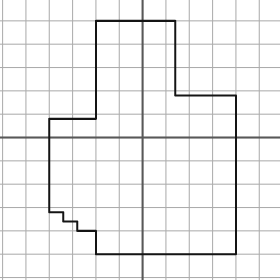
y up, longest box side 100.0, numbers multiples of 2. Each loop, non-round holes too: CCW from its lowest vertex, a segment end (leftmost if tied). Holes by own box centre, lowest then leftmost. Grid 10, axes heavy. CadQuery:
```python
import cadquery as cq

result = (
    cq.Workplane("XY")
    .moveTo(-20.0, -50.0)
    .lineTo(40.0, -50.0)
    .lineTo(40.0, 18.0)
    .lineTo(14.0, 18.0)
    .lineTo(14.0, 50.0)
    .lineTo(-20.0, 50.0)
    .lineTo(-20.0, 8.0)
    .lineTo(-40.0, 8.0)
    .lineTo(-40.0, -32.0)
    .lineTo(-34.0, -32.0)
    .lineTo(-34.0, -36.0)
    .lineTo(-28.0, -36.0)
    .lineTo(-28.0, -40.0)
    .lineTo(-20.0, -40.0)
    .close()
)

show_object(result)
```